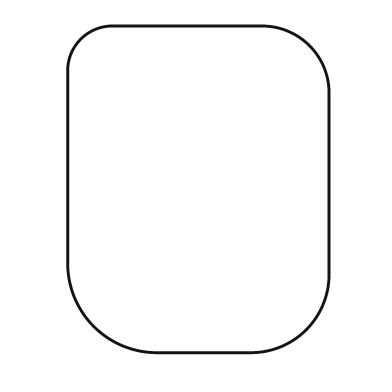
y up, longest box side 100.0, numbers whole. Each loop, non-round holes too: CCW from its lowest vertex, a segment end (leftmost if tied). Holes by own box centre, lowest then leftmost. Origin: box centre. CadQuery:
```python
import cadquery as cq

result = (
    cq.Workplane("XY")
    .moveTo(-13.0, -50.0)
    .lineTo(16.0, -50.0)
    .threePointArc((33.0, -43.0), (40.0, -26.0))
    .lineTo(40.0, 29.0)
    .threePointArc((34.0, 44.0), (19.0, 50.0))
    .lineTo(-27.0, 50.0)
    .threePointArc((-36.0, 46.0), (-40.0, 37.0))
    .lineTo(-40.0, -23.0)
    .threePointArc((-32.0, -42.0), (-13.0, -50.0))
    .close()
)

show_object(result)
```